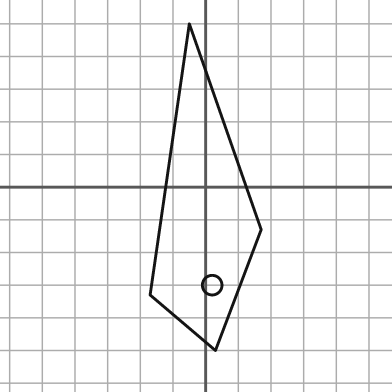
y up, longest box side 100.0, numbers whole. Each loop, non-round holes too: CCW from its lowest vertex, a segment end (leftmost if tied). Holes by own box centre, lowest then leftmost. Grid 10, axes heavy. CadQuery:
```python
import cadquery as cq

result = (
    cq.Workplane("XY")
    .moveTo(3.0, -50.0)
    .lineTo(17.0, -13.0)
    .lineTo(-5.0, 50.0)
    .lineTo(-17.0, -33.0)
    .close()
    .moveTo(2.0, -30.0)
    .circle(3.0)
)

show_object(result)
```